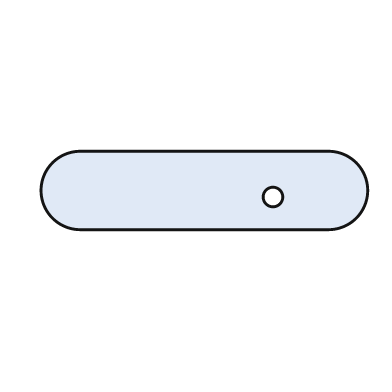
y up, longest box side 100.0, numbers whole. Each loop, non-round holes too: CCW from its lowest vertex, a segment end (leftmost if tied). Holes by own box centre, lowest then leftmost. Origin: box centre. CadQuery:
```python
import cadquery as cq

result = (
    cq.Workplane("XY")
    .moveTo(-38.0, -12.0)
    .lineTo(38.0, -12.0)
    .threePointArc((50.0, 0.0), (38.0, 12.0))
    .lineTo(-38.0, 12.0)
    .threePointArc((-50.0, 0.0), (-38.0, -12.0))
    .close()
    .moveTo(21.0, -2.0)
    .circle(3.0)
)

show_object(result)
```